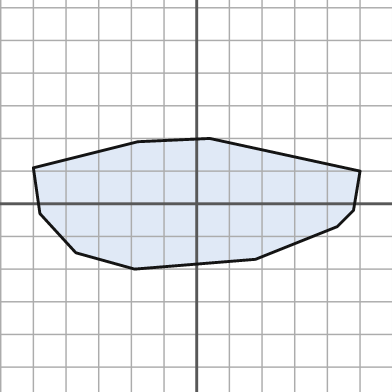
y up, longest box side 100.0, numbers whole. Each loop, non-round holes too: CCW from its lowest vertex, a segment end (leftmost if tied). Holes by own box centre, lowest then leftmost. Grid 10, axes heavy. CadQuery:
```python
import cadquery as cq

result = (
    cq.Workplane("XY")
    .moveTo(-19.0, -20.0)
    .lineTo(18.0, -17.0)
    .lineTo(43.0, -7.0)
    .lineTo(48.0, -2.0)
    .lineTo(50.0, 10.0)
    .lineTo(4.0, 20.0)
    .lineTo(-18.0, 19.0)
    .lineTo(-50.0, 11.0)
    .lineTo(-48.0, -3.0)
    .lineTo(-37.0, -15.0)
    .close()
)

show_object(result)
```